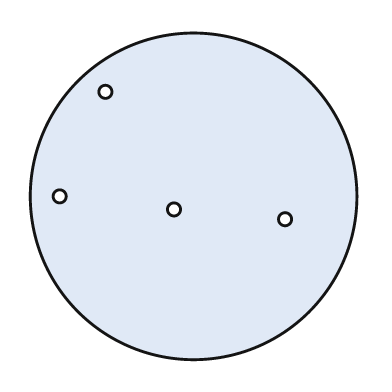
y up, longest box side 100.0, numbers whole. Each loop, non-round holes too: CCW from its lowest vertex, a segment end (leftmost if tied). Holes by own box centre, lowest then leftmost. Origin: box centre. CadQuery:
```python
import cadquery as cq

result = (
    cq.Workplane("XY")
    .moveTo(0.0, 0.0)
    .circle(50.0)
    .moveTo(28.0, -7.0)
    .circle(2.0)
    .moveTo(-6.0, -4.0)
    .circle(2.0)
    .moveTo(-41.0, 0.0)
    .circle(2.0)
    .moveTo(-27.0, 32.0)
    .circle(2.0)
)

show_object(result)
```